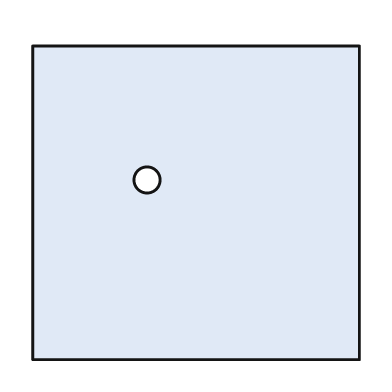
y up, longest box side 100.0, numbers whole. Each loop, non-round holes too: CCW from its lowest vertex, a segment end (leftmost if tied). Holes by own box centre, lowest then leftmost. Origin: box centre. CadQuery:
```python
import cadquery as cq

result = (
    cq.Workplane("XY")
    .moveTo(-50.0, -48.0)
    .lineTo(50.0, -48.0)
    .lineTo(50.0, 48.0)
    .lineTo(-50.0, 48.0)
    .close()
    .moveTo(-15.0, 7.0)
    .circle(4.0)
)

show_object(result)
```